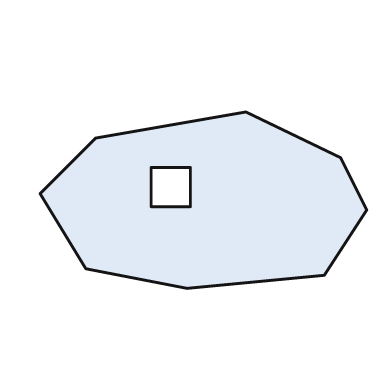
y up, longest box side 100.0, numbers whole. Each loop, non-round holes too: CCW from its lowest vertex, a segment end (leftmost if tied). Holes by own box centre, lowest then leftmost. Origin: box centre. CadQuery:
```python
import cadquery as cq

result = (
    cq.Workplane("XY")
    .moveTo(-5.0, -27.0)
    .lineTo(37.0, -23.0)
    .lineTo(50.0, -3.0)
    .lineTo(42.0, 13.0)
    .lineTo(13.0, 27.0)
    .lineTo(-33.0, 19.0)
    .lineTo(-50.0, 2.0)
    .lineTo(-36.0, -21.0)
    .close()
    .moveTo(-16.0, -2.0)
    .lineTo(-4.0, -2.0)
    .lineTo(-4.0, 10.0)
    .lineTo(-16.0, 10.0)
    .close()
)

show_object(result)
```